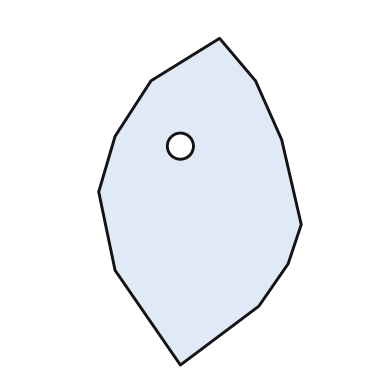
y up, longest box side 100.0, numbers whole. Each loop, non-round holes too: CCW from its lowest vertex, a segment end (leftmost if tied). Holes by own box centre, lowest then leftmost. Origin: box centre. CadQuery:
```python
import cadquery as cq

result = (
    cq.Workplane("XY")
    .moveTo(-6.0, -50.0)
    .lineTo(18.0, -32.0)
    .lineTo(27.0, -19.0)
    .lineTo(31.0, -7.0)
    .lineTo(25.0, 19.0)
    .lineTo(17.0, 37.0)
    .lineTo(6.0, 50.0)
    .lineTo(-15.0, 37.0)
    .lineTo(-26.0, 20.0)
    .lineTo(-31.0, 3.0)
    .lineTo(-26.0, -21.0)
    .close()
    .moveTo(-6.0, 17.0)
    .circle(4.0)
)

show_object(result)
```